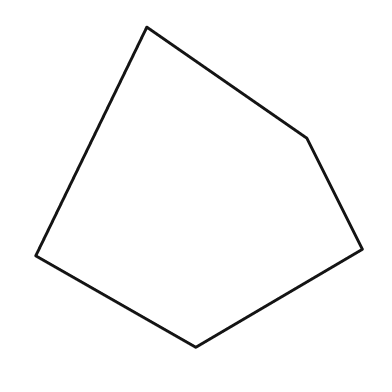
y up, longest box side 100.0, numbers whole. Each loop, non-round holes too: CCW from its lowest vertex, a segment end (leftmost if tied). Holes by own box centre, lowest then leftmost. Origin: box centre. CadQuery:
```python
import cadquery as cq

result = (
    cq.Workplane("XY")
    .moveTo(-1.0, -49.0)
    .lineTo(50.0, -19.0)
    .lineTo(33.0, 15.0)
    .lineTo(-16.0, 49.0)
    .lineTo(-50.0, -21.0)
    .close()
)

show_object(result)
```